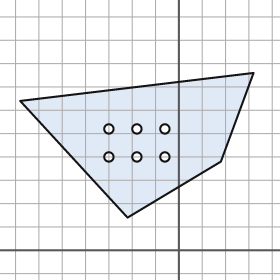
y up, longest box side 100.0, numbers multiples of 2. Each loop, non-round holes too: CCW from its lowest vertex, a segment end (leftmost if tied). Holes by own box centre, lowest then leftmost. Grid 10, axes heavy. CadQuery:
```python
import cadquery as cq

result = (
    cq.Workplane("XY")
    .moveTo(-22.0, 14.0)
    .lineTo(18.0, 38.0)
    .lineTo(32.0, 76.0)
    .lineTo(-68.0, 64.0)
    .close()
    .moveTo(-30.0, 40.0)
    .circle(2.0)
    .moveTo(-18.0, 40.0)
    .circle(2.0)
    .moveTo(-6.0, 40.0)
    .circle(2.0)
    .moveTo(-30.0, 52.0)
    .circle(2.0)
    .moveTo(-18.0, 52.0)
    .circle(2.0)
    .moveTo(-6.0, 52.0)
    .circle(2.0)
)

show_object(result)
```